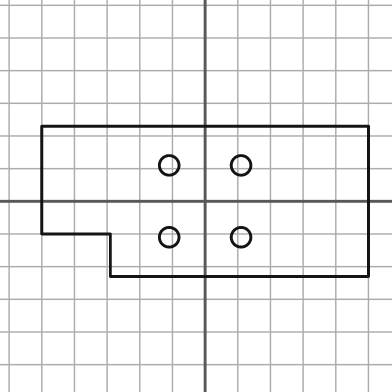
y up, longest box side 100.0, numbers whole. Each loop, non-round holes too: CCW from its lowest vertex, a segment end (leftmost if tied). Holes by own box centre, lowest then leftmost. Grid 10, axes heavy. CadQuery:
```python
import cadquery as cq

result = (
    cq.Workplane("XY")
    .moveTo(-29.0, -23.0)
    .lineTo(50.0, -23.0)
    .lineTo(50.0, 23.0)
    .lineTo(-50.0, 23.0)
    .lineTo(-50.0, -10.0)
    .lineTo(-29.0, -10.0)
    .close()
    .moveTo(-11.0, -11.0)
    .circle(3.0)
    .moveTo(11.0, -11.0)
    .circle(3.0)
    .moveTo(-11.0, 11.0)
    .circle(3.0)
    .moveTo(11.0, 11.0)
    .circle(3.0)
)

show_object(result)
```